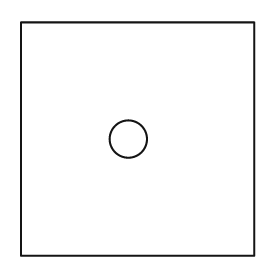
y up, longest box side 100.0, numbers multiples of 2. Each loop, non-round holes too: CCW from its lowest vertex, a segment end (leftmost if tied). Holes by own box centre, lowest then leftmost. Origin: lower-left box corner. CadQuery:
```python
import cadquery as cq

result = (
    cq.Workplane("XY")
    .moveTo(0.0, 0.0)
    .lineTo(100.0, 0.0)
    .lineTo(100.0, 100.0)
    .lineTo(0.0, 100.0)
    .close()
    .moveTo(46.0, 50.0)
    .circle(8.0)
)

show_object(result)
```